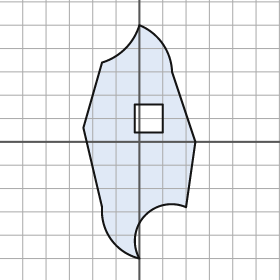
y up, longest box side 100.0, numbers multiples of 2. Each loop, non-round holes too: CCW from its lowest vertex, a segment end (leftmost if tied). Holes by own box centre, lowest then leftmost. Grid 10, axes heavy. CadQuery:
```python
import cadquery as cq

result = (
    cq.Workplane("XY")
    .moveTo(0.0, -50.0)
    .threePointArc((2.0, -32.0), (20.0, -28.0))
    .lineTo(24.0, 0.0)
    .lineTo(14.0, 30.0)
    .threePointArc((10.0, 42.0), (0.0, 50.0))
    .threePointArc((-6.0, 40.0), (-16.0, 34.0))
    .lineTo(-24.0, 6.0)
    .lineTo(-16.0, -28.0)
    .threePointArc((-12.0, -42.0), (0.0, -50.0))
    .close()
    .moveTo(-2.0, 4.0)
    .lineTo(10.0, 4.0)
    .lineTo(10.0, 16.0)
    .lineTo(-2.0, 16.0)
    .close()
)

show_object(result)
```